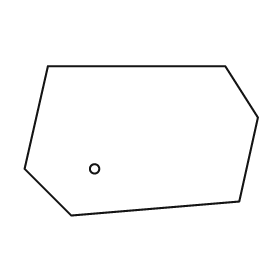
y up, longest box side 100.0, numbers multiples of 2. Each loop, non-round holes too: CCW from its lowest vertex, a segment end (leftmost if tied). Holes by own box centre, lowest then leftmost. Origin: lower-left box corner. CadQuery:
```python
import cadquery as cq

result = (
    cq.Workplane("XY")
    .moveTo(20.0, 0.0)
    .lineTo(92.0, 6.0)
    .lineTo(100.0, 42.0)
    .lineTo(86.0, 64.0)
    .lineTo(10.0, 64.0)
    .lineTo(0.0, 20.0)
    .close()
    .moveTo(30.0, 20.0)
    .circle(2.0)
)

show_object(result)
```